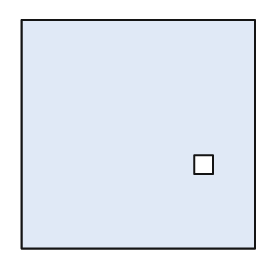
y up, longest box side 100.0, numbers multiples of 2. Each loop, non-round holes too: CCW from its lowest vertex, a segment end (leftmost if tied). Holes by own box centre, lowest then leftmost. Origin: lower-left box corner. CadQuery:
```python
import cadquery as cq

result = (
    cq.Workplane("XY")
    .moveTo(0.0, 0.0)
    .lineTo(100.0, 0.0)
    .lineTo(100.0, 98.0)
    .lineTo(0.0, 98.0)
    .close()
    .moveTo(74.0, 32.0)
    .lineTo(82.0, 32.0)
    .lineTo(82.0, 40.0)
    .lineTo(74.0, 40.0)
    .close()
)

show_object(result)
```